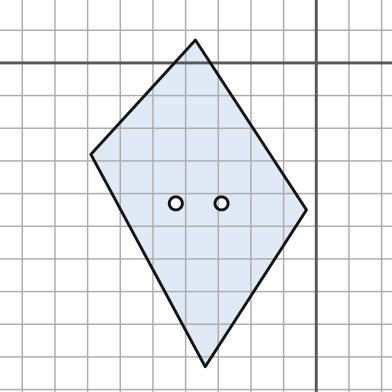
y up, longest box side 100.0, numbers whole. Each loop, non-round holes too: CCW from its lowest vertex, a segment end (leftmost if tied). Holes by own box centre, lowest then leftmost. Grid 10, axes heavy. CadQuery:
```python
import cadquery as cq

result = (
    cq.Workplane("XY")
    .moveTo(-34.0, -93.0)
    .lineTo(-3.0, -45.0)
    .lineTo(-37.0, 7.0)
    .lineTo(-69.0, -28.0)
    .close()
    .moveTo(-43.0, -43.0)
    .circle(2.0)
    .moveTo(-29.0, -43.0)
    .circle(2.0)
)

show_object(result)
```